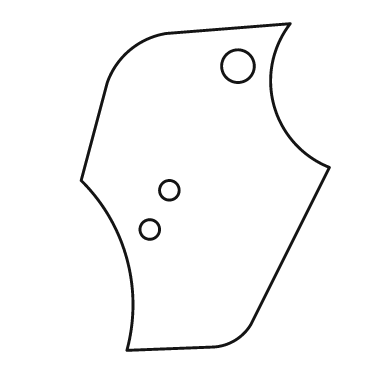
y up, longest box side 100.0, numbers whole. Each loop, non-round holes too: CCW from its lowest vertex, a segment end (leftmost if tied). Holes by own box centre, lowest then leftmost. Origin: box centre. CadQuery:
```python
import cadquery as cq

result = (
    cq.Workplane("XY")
    .moveTo(-24.0, -50.0)
    .lineTo(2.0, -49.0)
    .threePointArc((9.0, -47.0), (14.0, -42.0))
    .lineTo(38.0, 6.0)
    .threePointArc((21.0, 25.0), (26.0, 50.0))
    .lineTo(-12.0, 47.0)
    .threePointArc((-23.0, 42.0), (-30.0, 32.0))
    .lineTo(-38.0, 2.0)
    .threePointArc((-24.0, -22.0), (-24.0, -50.0))
    .close()
    .moveTo(-17.0, -13.0)
    .circle(3.0)
    .moveTo(-11.0, -1.0)
    .circle(3.0)
    .moveTo(10.0, 37.0)
    .circle(5.0)
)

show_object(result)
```